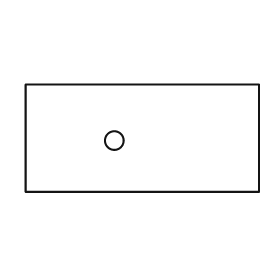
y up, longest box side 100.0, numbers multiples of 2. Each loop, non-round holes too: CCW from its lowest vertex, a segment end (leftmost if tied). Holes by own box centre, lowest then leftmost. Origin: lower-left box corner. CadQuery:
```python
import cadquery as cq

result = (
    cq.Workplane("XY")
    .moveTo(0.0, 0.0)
    .lineTo(100.0, 0.0)
    .lineTo(100.0, 46.0)
    .lineTo(0.0, 46.0)
    .close()
    .moveTo(38.0, 22.0)
    .circle(4.0)
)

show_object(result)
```